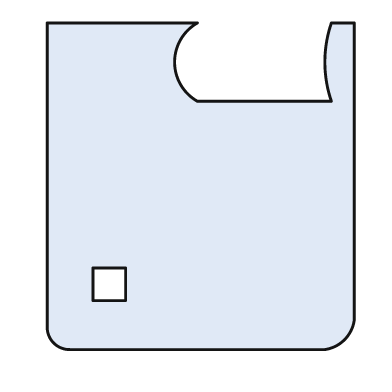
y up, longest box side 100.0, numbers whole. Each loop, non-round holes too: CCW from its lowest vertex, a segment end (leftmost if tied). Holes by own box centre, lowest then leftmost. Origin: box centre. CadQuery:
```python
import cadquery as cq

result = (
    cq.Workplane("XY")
    .moveTo(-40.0, -50.0)
    .lineTo(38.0, -50.0)
    .threePointArc((44.0, -47.0), (47.0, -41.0))
    .lineTo(47.0, 50.0)
    .lineTo(40.0, 50.0)
    .threePointArc((38.0, 38.0), (40.0, 26.0))
    .lineTo(-1.0, 26.0)
    .threePointArc((-8.0, 38.0), (-1.0, 50.0))
    .lineTo(-47.0, 50.0)
    .lineTo(-47.0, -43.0)
    .threePointArc((-45.0, -48.0), (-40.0, -50.0))
    .close()
    .moveTo(-33.0, -35.0)
    .lineTo(-23.0, -35.0)
    .lineTo(-23.0, -25.0)
    .lineTo(-33.0, -25.0)
    .close()
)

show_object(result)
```